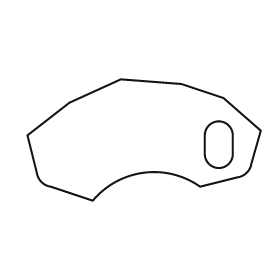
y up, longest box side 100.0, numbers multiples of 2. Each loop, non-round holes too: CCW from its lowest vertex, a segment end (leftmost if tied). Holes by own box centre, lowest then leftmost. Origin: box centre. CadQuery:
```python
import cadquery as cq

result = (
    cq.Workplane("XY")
    .moveTo(-22.0, -26.0)
    .threePointArc((0.0, -14.0), (24.0, -20.0))
    .lineTo(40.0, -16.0)
    .threePointArc((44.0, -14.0), (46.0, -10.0))
    .lineTo(50.0, 4.0)
    .lineTo(34.0, 18.0)
    .lineTo(16.0, 24.0)
    .lineTo(-10.0, 26.0)
    .lineTo(-32.0, 16.0)
    .lineTo(-50.0, 2.0)
    .lineTo(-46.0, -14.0)
    .threePointArc((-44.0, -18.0), (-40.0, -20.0))
    .close()
    .moveTo(26.0, -6.0)
    .threePointArc((32.0, -12.0), (38.0, -6.0))
    .lineTo(38.0, 2.0)
    .threePointArc((32.0, 8.0), (26.0, 2.0))
    .close()
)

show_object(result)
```